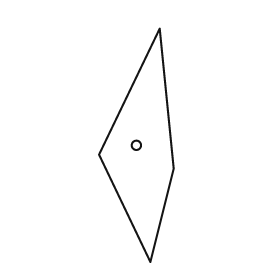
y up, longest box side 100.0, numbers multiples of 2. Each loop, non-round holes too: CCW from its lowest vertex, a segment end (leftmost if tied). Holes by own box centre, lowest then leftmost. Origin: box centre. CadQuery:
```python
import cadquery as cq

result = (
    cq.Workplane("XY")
    .moveTo(6.0, -50.0)
    .lineTo(16.0, -10.0)
    .lineTo(10.0, 50.0)
    .lineTo(-16.0, -4.0)
    .close()
    .moveTo(0.0, 0.0)
    .circle(2.0)
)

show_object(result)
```